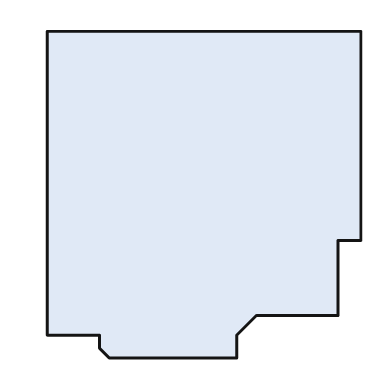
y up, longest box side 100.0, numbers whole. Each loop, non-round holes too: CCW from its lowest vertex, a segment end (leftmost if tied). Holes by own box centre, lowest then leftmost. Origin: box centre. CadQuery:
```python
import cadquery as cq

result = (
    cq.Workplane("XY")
    .moveTo(-29.0, -50.0)
    .lineTo(10.0, -50.0)
    .lineTo(10.0, -43.0)
    .lineTo(16.0, -37.0)
    .lineTo(41.0, -37.0)
    .lineTo(41.0, -14.0)
    .lineTo(48.0, -14.0)
    .lineTo(48.0, 50.0)
    .lineTo(-48.0, 50.0)
    .lineTo(-48.0, -43.0)
    .lineTo(-32.0, -43.0)
    .lineTo(-32.0, -47.0)
    .close()
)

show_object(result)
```